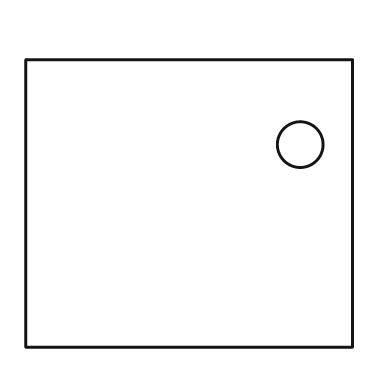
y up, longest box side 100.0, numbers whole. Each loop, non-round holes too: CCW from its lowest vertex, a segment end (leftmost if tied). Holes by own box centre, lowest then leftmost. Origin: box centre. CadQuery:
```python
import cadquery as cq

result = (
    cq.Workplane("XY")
    .moveTo(-50.0, -44.0)
    .lineTo(50.0, -44.0)
    .lineTo(50.0, 44.0)
    .lineTo(-50.0, 44.0)
    .close()
    .moveTo(34.0, 18.0)
    .circle(7.0)
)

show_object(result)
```